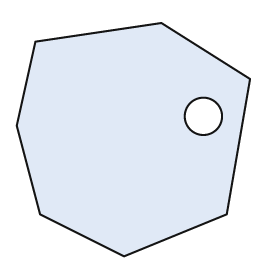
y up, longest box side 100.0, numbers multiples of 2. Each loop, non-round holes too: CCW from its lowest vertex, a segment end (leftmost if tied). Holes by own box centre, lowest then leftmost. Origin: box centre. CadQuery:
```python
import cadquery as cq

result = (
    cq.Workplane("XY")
    .moveTo(-4.0, -50.0)
    .lineTo(40.0, -32.0)
    .lineTo(50.0, 26.0)
    .lineTo(12.0, 50.0)
    .lineTo(-42.0, 42.0)
    .lineTo(-50.0, 6.0)
    .lineTo(-40.0, -32.0)
    .close()
    .moveTo(30.0, 10.0)
    .circle(8.0)
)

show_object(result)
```